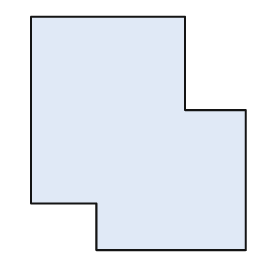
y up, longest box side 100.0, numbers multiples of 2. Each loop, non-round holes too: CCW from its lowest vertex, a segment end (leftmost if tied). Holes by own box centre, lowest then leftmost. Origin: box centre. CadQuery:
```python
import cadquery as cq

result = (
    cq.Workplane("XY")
    .moveTo(-18.0, -50.0)
    .lineTo(46.0, -50.0)
    .lineTo(46.0, 10.0)
    .lineTo(20.0, 10.0)
    .lineTo(20.0, 50.0)
    .lineTo(-46.0, 50.0)
    .lineTo(-46.0, -30.0)
    .lineTo(-18.0, -30.0)
    .close()
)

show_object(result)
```